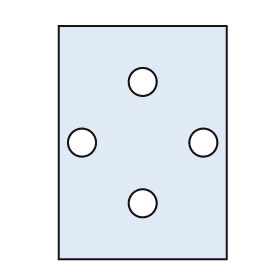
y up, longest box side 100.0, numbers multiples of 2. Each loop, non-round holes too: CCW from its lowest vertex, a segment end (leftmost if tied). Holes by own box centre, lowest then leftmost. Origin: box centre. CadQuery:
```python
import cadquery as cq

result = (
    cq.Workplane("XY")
    .moveTo(-36.0, -50.0)
    .lineTo(36.0, -50.0)
    .lineTo(36.0, 50.0)
    .lineTo(-36.0, 50.0)
    .close()
    .moveTo(0.0, -26.0)
    .circle(6.0)
    .moveTo(-26.0, 0.0)
    .circle(6.0)
    .moveTo(26.0, 0.0)
    .circle(6.0)
    .moveTo(0.0, 26.0)
    .circle(6.0)
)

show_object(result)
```